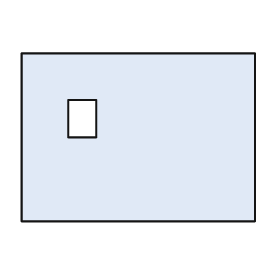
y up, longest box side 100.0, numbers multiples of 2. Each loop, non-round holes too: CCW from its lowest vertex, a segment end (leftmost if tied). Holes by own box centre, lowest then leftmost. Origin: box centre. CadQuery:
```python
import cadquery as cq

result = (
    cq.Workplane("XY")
    .moveTo(-50.0, -36.0)
    .lineTo(50.0, -36.0)
    .lineTo(50.0, 36.0)
    .lineTo(-50.0, 36.0)
    .close()
    .moveTo(-30.0, 0.0)
    .lineTo(-18.0, 0.0)
    .lineTo(-18.0, 16.0)
    .lineTo(-30.0, 16.0)
    .close()
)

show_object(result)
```